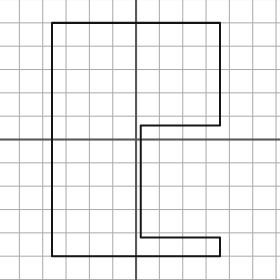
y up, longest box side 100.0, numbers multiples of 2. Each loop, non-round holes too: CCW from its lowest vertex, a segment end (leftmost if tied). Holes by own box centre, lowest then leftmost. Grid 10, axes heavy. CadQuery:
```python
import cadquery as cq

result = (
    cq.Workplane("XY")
    .moveTo(-36.0, -50.0)
    .lineTo(36.0, -50.0)
    .lineTo(36.0, -42.0)
    .lineTo(2.0, -42.0)
    .lineTo(2.0, 6.0)
    .lineTo(36.0, 6.0)
    .lineTo(36.0, 50.0)
    .lineTo(-36.0, 50.0)
    .close()
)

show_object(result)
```